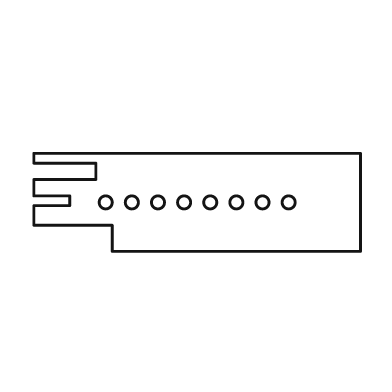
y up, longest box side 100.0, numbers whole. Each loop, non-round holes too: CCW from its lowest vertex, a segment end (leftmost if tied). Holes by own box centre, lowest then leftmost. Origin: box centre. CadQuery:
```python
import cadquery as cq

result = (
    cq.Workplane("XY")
    .moveTo(-26.0, -15.0)
    .lineTo(50.0, -15.0)
    .lineTo(50.0, 15.0)
    .lineTo(-50.0, 15.0)
    .lineTo(-50.0, 12.0)
    .lineTo(-31.0, 12.0)
    .lineTo(-31.0, 7.0)
    .lineTo(-50.0, 7.0)
    .lineTo(-50.0, 2.0)
    .lineTo(-39.0, 2.0)
    .lineTo(-39.0, -1.0)
    .lineTo(-50.0, -1.0)
    .lineTo(-50.0, -7.0)
    .lineTo(-26.0, -7.0)
    .close()
    .moveTo(-28.0, 0.0)
    .circle(2.0)
    .moveTo(-20.0, 0.0)
    .circle(2.0)
    .moveTo(-12.0, 0.0)
    .circle(2.0)
    .moveTo(-4.0, 0.0)
    .circle(2.0)
    .moveTo(4.0, 0.0)
    .circle(2.0)
    .moveTo(12.0, 0.0)
    .circle(2.0)
    .moveTo(20.0, 0.0)
    .circle(2.0)
    .moveTo(28.0, 0.0)
    .circle(2.0)
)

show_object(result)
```